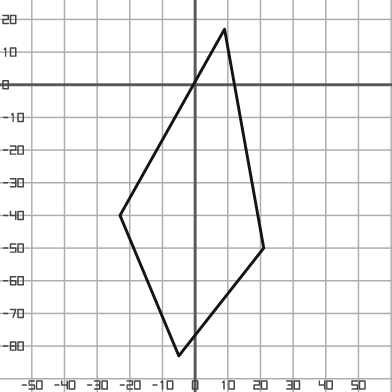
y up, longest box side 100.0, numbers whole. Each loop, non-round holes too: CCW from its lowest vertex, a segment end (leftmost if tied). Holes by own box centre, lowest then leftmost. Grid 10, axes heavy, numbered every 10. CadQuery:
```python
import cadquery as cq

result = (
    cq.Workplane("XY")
    .moveTo(-5.0, -83.0)
    .lineTo(21.0, -50.0)
    .lineTo(9.0, 17.0)
    .lineTo(-23.0, -40.0)
    .close()
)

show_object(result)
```